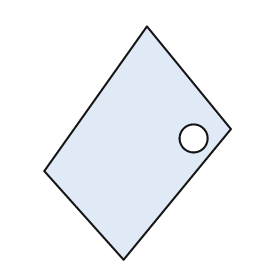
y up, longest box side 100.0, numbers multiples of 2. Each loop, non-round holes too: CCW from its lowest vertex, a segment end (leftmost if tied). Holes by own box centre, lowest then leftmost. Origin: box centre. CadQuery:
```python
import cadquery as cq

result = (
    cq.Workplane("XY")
    .moveTo(-6.0, -50.0)
    .lineTo(40.0, 6.0)
    .lineTo(4.0, 50.0)
    .lineTo(-40.0, -12.0)
    .close()
    .moveTo(24.0, 2.0)
    .circle(6.0)
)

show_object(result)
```